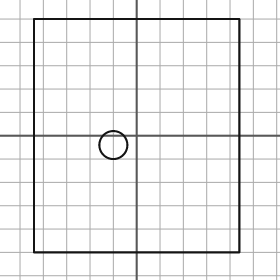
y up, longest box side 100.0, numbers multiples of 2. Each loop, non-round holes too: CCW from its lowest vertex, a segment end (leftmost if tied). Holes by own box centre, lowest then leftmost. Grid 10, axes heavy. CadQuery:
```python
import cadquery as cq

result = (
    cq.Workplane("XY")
    .moveTo(-44.0, -50.0)
    .lineTo(44.0, -50.0)
    .lineTo(44.0, 50.0)
    .lineTo(-44.0, 50.0)
    .close()
    .moveTo(-10.0, -4.0)
    .circle(6.0)
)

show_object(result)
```